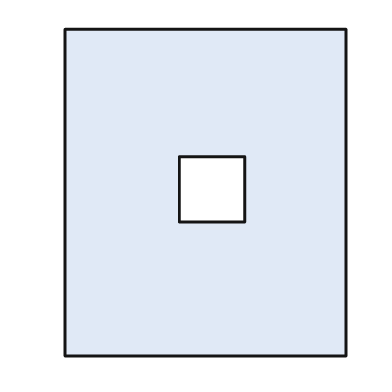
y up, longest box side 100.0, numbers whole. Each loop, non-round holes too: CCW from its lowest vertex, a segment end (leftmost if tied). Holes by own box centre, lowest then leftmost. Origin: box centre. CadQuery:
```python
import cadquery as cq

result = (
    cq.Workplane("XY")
    .moveTo(-43.0, -50.0)
    .lineTo(43.0, -50.0)
    .lineTo(43.0, 50.0)
    .lineTo(-43.0, 50.0)
    .close()
    .moveTo(-8.0, -9.0)
    .lineTo(12.0, -9.0)
    .lineTo(12.0, 11.0)
    .lineTo(-8.0, 11.0)
    .close()
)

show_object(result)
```